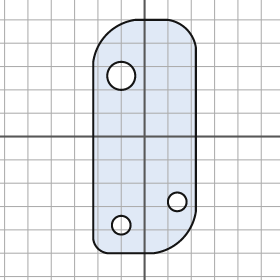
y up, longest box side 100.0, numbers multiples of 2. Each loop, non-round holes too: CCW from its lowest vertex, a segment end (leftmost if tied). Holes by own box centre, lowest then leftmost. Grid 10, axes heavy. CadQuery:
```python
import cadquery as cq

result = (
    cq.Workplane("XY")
    .moveTo(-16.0, -50.0)
    .lineTo(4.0, -50.0)
    .threePointArc((16.0, -44.0), (22.0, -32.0))
    .lineTo(22.0, 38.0)
    .threePointArc((18.0, 46.0), (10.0, 50.0))
    .lineTo(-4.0, 50.0)
    .threePointArc((-16.0, 44.0), (-22.0, 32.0))
    .lineTo(-22.0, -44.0)
    .threePointArc((-20.0, -48.0), (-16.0, -50.0))
    .close()
    .moveTo(-10.0, -38.0)
    .circle(4.0)
    .moveTo(14.0, -28.0)
    .circle(4.0)
    .moveTo(-10.0, 26.0)
    .circle(6.0)
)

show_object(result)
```